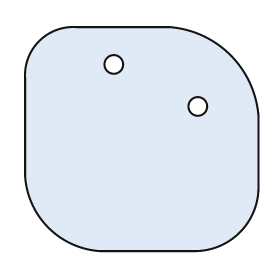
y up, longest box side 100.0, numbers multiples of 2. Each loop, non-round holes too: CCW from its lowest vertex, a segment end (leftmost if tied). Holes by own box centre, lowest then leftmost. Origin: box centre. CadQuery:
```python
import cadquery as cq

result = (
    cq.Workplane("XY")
    .moveTo(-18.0, -48.0)
    .lineTo(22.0, -48.0)
    .threePointArc((42.0, -40.0), (50.0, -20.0))
    .lineTo(50.0, 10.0)
    .threePointArc((38.0, 36.0), (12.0, 48.0))
    .lineTo(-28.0, 48.0)
    .threePointArc((-44.0, 42.0), (-50.0, 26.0))
    .lineTo(-50.0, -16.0)
    .threePointArc((-40.0, -38.0), (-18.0, -48.0))
    .close()
    .moveTo(24.0, 14.0)
    .circle(4.0)
    .moveTo(-12.0, 32.0)
    .circle(4.0)
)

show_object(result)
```